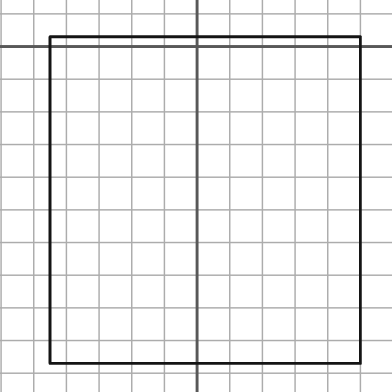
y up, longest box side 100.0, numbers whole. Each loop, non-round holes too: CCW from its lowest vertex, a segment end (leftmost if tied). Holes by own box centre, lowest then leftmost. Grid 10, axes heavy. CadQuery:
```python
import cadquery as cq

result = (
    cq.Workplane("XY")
    .moveTo(-45.0, -97.0)
    .lineTo(50.0, -97.0)
    .lineTo(50.0, 3.0)
    .lineTo(-45.0, 3.0)
    .close()
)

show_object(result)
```